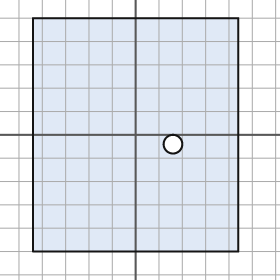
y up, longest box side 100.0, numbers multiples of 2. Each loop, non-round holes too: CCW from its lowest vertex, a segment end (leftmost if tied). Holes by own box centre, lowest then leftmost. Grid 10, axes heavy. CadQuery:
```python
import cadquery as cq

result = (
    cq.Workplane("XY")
    .moveTo(-44.0, -50.0)
    .lineTo(44.0, -50.0)
    .lineTo(44.0, 50.0)
    .lineTo(-44.0, 50.0)
    .close()
    .moveTo(16.0, -4.0)
    .circle(4.0)
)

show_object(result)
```